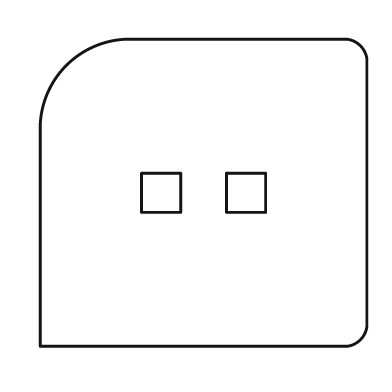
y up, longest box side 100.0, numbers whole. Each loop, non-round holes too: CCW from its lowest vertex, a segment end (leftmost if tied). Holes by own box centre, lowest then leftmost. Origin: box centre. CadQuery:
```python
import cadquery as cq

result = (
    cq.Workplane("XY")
    .moveTo(-50.0, -47.0)
    .lineTo(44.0, -47.0)
    .threePointArc((48.0, -45.0), (50.0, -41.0))
    .lineTo(50.0, 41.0)
    .threePointArc((48.0, 45.0), (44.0, 47.0))
    .lineTo(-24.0, 47.0)
    .threePointArc((-42.0, 39.0), (-50.0, 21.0))
    .close()
    .moveTo(-19.0, -6.0)
    .lineTo(-7.0, -6.0)
    .lineTo(-7.0, 6.0)
    .lineTo(-19.0, 6.0)
    .close()
    .moveTo(7.0, -6.0)
    .lineTo(19.0, -6.0)
    .lineTo(19.0, 6.0)
    .lineTo(7.0, 6.0)
    .close()
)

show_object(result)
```